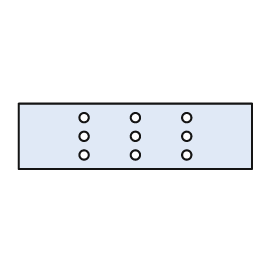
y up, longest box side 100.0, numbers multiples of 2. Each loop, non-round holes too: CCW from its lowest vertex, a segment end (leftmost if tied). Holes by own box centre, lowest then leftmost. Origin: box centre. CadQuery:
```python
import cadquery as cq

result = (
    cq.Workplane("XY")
    .moveTo(-50.0, -14.0)
    .lineTo(50.0, -14.0)
    .lineTo(50.0, 14.0)
    .lineTo(-50.0, 14.0)
    .close()
    .moveTo(-22.0, -8.0)
    .circle(2.0)
    .moveTo(0.0, -8.0)
    .circle(2.0)
    .moveTo(22.0, -8.0)
    .circle(2.0)
    .moveTo(-22.0, 0.0)
    .circle(2.0)
    .moveTo(0.0, 0.0)
    .circle(2.0)
    .moveTo(22.0, 0.0)
    .circle(2.0)
    .moveTo(-22.0, 8.0)
    .circle(2.0)
    .moveTo(0.0, 8.0)
    .circle(2.0)
    .moveTo(22.0, 8.0)
    .circle(2.0)
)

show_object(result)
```